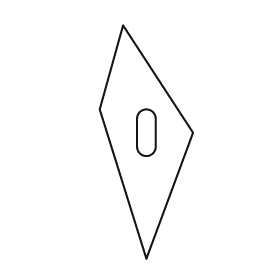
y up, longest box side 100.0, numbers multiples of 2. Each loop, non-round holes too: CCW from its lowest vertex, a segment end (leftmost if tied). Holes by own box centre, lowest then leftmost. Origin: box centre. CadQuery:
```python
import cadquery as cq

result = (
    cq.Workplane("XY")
    .moveTo(0.0, -50.0)
    .lineTo(20.0, 4.0)
    .lineTo(-10.0, 50.0)
    .lineTo(-20.0, 14.0)
    .close()
    .moveTo(-4.0, -2.0)
    .threePointArc((0.0, -6.0), (4.0, -2.0))
    .lineTo(4.0, 10.0)
    .threePointArc((0.0, 14.0), (-4.0, 10.0))
    .close()
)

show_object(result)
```